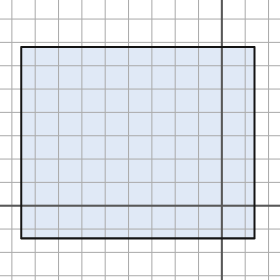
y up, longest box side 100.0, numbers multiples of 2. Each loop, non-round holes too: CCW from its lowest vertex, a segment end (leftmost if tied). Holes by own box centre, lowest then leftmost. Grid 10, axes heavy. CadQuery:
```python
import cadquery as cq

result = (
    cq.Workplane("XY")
    .moveTo(-86.0, -14.0)
    .lineTo(14.0, -14.0)
    .lineTo(14.0, 68.0)
    .lineTo(-86.0, 68.0)
    .close()
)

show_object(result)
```